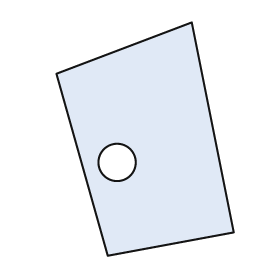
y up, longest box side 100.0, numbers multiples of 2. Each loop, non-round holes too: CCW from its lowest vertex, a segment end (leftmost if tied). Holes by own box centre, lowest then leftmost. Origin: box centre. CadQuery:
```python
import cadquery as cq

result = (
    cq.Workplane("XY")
    .moveTo(-16.0, -50.0)
    .lineTo(38.0, -40.0)
    .lineTo(20.0, 50.0)
    .lineTo(-38.0, 28.0)
    .close()
    .moveTo(-12.0, -10.0)
    .circle(8.0)
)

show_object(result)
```